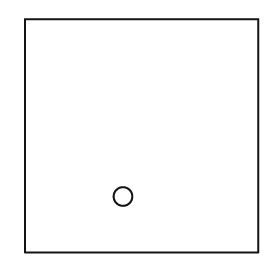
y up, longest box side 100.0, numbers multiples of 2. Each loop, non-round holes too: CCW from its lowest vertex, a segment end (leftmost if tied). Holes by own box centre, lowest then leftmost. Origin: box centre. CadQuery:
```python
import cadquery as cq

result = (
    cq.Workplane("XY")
    .moveTo(-50.0, -50.0)
    .lineTo(50.0, -50.0)
    .lineTo(50.0, 50.0)
    .lineTo(-50.0, 50.0)
    .close()
    .moveTo(-8.0, -26.0)
    .circle(4.0)
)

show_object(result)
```